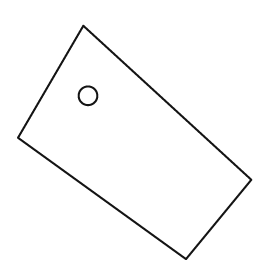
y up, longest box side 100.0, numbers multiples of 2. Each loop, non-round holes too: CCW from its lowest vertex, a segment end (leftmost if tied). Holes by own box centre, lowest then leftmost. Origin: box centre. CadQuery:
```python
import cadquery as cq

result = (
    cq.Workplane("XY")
    .moveTo(22.0, -50.0)
    .lineTo(50.0, -16.0)
    .lineTo(-22.0, 50.0)
    .lineTo(-50.0, 2.0)
    .close()
    .moveTo(-20.0, 20.0)
    .circle(4.0)
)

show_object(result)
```